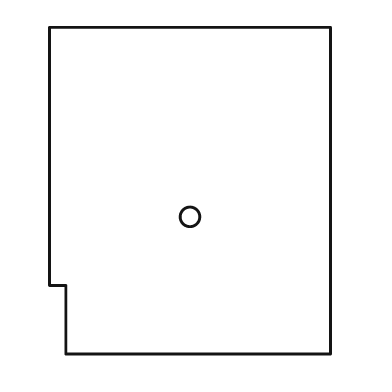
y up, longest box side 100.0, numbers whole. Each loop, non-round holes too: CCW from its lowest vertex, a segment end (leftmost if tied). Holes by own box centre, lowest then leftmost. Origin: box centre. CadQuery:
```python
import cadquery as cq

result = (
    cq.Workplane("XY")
    .moveTo(-38.0, -50.0)
    .lineTo(43.0, -50.0)
    .lineTo(43.0, 50.0)
    .lineTo(-43.0, 50.0)
    .lineTo(-43.0, -29.0)
    .lineTo(-38.0, -29.0)
    .close()
    .moveTo(0.0, -8.0)
    .circle(3.0)
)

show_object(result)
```